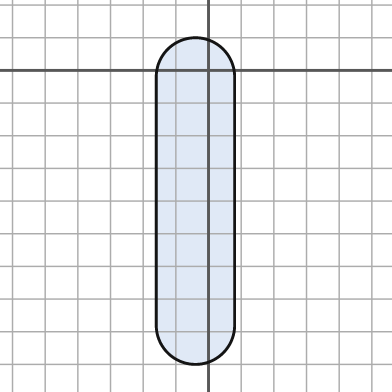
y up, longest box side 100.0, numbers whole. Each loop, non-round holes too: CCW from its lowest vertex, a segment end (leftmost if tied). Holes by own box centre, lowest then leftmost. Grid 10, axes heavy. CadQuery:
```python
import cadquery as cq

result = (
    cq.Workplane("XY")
    .moveTo(-16.0, -78.0)
    .threePointArc((-4.0, -90.0), (8.0, -78.0))
    .lineTo(8.0, -2.0)
    .threePointArc((-4.0, 10.0), (-16.0, -2.0))
    .close()
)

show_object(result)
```